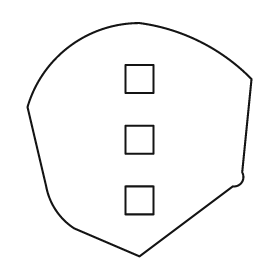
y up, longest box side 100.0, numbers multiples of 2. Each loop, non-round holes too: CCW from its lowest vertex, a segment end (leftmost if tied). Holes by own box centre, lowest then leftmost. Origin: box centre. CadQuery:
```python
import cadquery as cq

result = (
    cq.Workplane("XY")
    .moveTo(0.0, -50.0)
    .lineTo(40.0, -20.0)
    .threePointArc((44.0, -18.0), (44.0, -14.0))
    .lineTo(48.0, 26.0)
    .threePointArc((26.0, 42.0), (0.0, 50.0))
    .threePointArc((-30.0, 40.0), (-48.0, 14.0))
    .lineTo(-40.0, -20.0)
    .threePointArc((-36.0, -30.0), (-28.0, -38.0))
    .close()
    .moveTo(-6.0, -32.0)
    .lineTo(6.0, -32.0)
    .lineTo(6.0, -20.0)
    .lineTo(-6.0, -20.0)
    .close()
    .moveTo(-6.0, -6.0)
    .lineTo(6.0, -6.0)
    .lineTo(6.0, 6.0)
    .lineTo(-6.0, 6.0)
    .close()
    .moveTo(-6.0, 20.0)
    .lineTo(6.0, 20.0)
    .lineTo(6.0, 32.0)
    .lineTo(-6.0, 32.0)
    .close()
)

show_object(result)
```